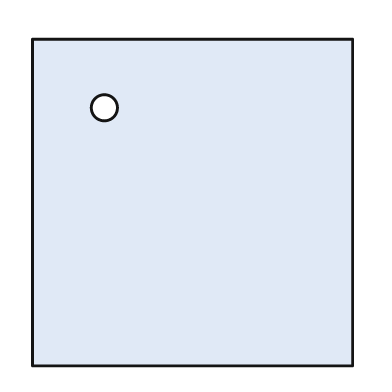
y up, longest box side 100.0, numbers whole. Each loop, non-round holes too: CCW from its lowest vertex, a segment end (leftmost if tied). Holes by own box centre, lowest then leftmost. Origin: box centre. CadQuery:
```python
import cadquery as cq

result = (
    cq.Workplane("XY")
    .moveTo(-49.0, -50.0)
    .lineTo(49.0, -50.0)
    .lineTo(49.0, 50.0)
    .lineTo(-49.0, 50.0)
    .close()
    .moveTo(-27.0, 29.0)
    .circle(4.0)
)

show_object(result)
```